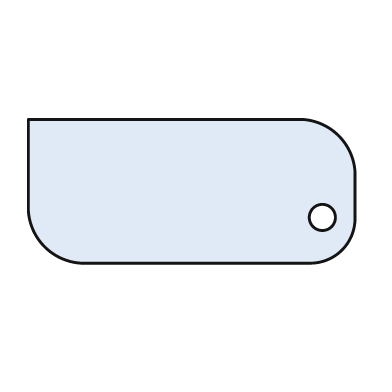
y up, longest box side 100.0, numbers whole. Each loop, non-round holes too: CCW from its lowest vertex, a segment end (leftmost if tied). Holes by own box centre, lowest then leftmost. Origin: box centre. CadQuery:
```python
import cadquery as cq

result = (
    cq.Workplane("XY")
    .moveTo(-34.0, -22.0)
    .lineTo(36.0, -22.0)
    .threePointArc((46.0, -18.0), (50.0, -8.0))
    .lineTo(50.0, 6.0)
    .threePointArc((45.0, 17.0), (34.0, 22.0))
    .lineTo(-50.0, 22.0)
    .lineTo(-50.0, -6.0)
    .threePointArc((-45.0, -17.0), (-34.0, -22.0))
    .close()
    .moveTo(40.0, -8.0)
    .circle(4.0)
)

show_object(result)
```